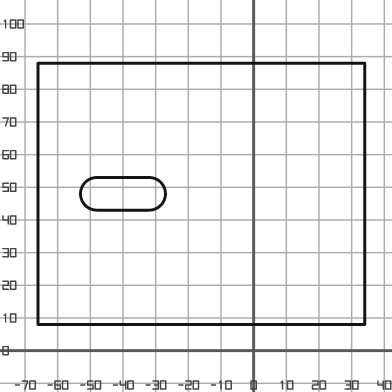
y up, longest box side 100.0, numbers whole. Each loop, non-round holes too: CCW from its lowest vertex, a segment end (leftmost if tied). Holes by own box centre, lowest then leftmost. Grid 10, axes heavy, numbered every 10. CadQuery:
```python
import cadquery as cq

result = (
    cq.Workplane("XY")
    .moveTo(-66.0, 8.0)
    .lineTo(34.0, 8.0)
    .lineTo(34.0, 88.0)
    .lineTo(-66.0, 88.0)
    .close()
    .moveTo(-48.0, 43.0)
    .lineTo(-32.0, 43.0)
    .threePointArc((-27.0, 48.0), (-32.0, 53.0))
    .lineTo(-48.0, 53.0)
    .threePointArc((-53.0, 48.0), (-48.0, 43.0))
    .close()
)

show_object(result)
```